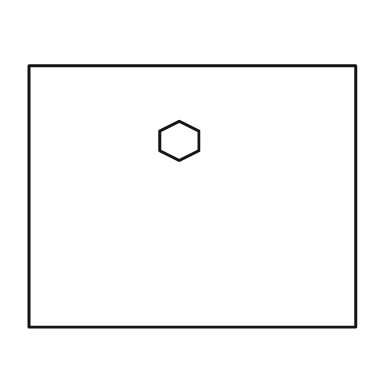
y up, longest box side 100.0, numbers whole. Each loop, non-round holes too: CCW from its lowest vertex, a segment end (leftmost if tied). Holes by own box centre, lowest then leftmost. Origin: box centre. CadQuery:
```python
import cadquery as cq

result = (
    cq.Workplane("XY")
    .moveTo(-50.0, -40.0)
    .lineTo(50.0, -40.0)
    .lineTo(50.0, 40.0)
    .lineTo(-50.0, 40.0)
    .close()
    .moveTo(-4.0, 11.0)
    .lineTo(2.0, 14.0)
    .lineTo(2.0, 20.0)
    .lineTo(-4.0, 23.0)
    .lineTo(-10.0, 20.0)
    .lineTo(-10.0, 14.0)
    .close()
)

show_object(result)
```